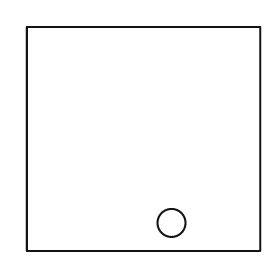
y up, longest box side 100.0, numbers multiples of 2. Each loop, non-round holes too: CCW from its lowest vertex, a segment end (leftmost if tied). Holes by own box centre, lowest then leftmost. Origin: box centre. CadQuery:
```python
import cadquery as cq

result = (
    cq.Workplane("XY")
    .moveTo(-50.0, -48.0)
    .lineTo(50.0, -48.0)
    .lineTo(50.0, 48.0)
    .lineTo(-50.0, 48.0)
    .close()
    .moveTo(12.0, -36.0)
    .circle(6.0)
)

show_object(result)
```